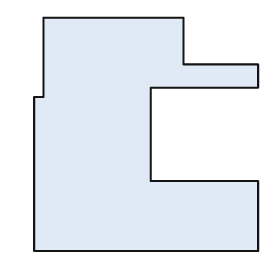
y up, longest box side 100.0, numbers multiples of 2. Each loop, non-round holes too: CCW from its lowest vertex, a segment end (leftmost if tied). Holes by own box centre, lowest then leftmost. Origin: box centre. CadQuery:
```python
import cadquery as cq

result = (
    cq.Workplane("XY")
    .moveTo(-48.0, -50.0)
    .lineTo(48.0, -50.0)
    .lineTo(48.0, -20.0)
    .lineTo(2.0, -20.0)
    .lineTo(2.0, 20.0)
    .lineTo(48.0, 20.0)
    .lineTo(48.0, 30.0)
    .lineTo(16.0, 30.0)
    .lineTo(16.0, 50.0)
    .lineTo(-44.0, 50.0)
    .lineTo(-44.0, 16.0)
    .lineTo(-48.0, 16.0)
    .close()
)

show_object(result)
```